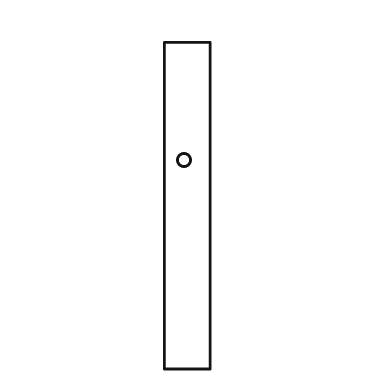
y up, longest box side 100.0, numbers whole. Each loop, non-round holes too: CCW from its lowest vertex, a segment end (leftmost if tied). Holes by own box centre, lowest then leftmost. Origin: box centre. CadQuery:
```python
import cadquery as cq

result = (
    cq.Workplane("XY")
    .moveTo(-7.0, -50.0)
    .lineTo(7.0, -50.0)
    .lineTo(7.0, 50.0)
    .lineTo(-7.0, 50.0)
    .close()
    .moveTo(-1.0, 14.0)
    .circle(2.0)
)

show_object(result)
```